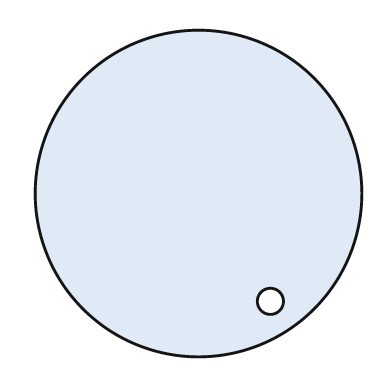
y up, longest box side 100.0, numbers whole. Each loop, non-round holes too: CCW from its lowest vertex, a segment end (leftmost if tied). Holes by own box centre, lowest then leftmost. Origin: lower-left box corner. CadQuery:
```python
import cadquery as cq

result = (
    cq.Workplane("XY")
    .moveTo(50.0, 50.0)
    .circle(50.0)
    .moveTo(72.0, 17.0)
    .circle(4.0)
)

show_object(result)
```